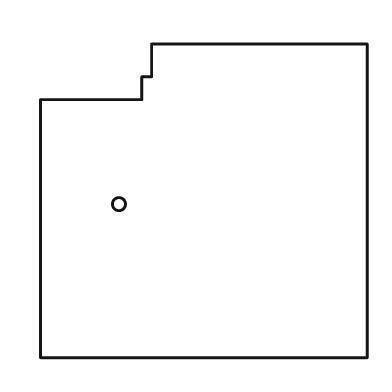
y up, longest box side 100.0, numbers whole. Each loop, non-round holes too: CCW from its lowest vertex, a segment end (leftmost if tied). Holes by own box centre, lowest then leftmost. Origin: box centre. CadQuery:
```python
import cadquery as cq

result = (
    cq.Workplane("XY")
    .moveTo(-50.0, -48.0)
    .lineTo(50.0, -48.0)
    .lineTo(50.0, 48.0)
    .lineTo(-16.0, 48.0)
    .lineTo(-16.0, 38.0)
    .lineTo(-19.0, 38.0)
    .lineTo(-19.0, 31.0)
    .lineTo(-50.0, 31.0)
    .close()
    .moveTo(-26.0, -1.0)
    .circle(2.0)
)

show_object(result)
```